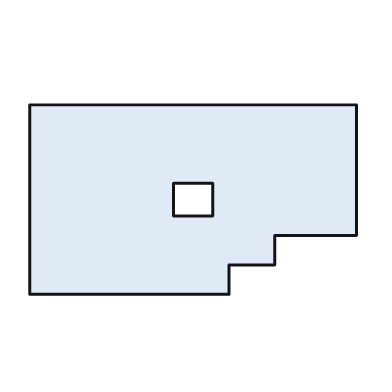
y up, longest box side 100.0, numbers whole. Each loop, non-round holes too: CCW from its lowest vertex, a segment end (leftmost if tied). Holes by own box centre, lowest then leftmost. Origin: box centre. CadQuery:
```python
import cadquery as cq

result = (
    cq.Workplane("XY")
    .moveTo(-50.0, -29.0)
    .lineTo(11.0, -29.0)
    .lineTo(11.0, -20.0)
    .lineTo(25.0, -20.0)
    .lineTo(25.0, -11.0)
    .lineTo(50.0, -11.0)
    .lineTo(50.0, 29.0)
    .lineTo(-50.0, 29.0)
    .close()
    .moveTo(-6.0, -5.0)
    .lineTo(6.0, -5.0)
    .lineTo(6.0, 5.0)
    .lineTo(-6.0, 5.0)
    .close()
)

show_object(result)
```